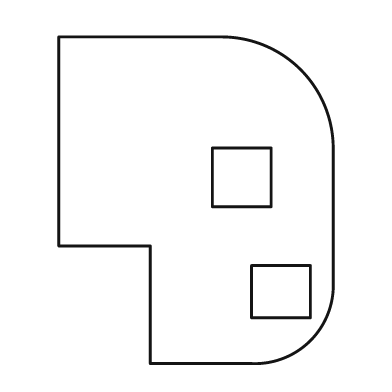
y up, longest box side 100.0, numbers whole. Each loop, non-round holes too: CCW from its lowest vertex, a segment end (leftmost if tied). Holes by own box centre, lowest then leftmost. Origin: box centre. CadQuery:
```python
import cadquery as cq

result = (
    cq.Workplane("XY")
    .moveTo(-14.0, -50.0)
    .lineTo(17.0, -50.0)
    .threePointArc((35.0, -43.0), (42.0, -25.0))
    .lineTo(42.0, 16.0)
    .threePointArc((32.0, 40.0), (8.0, 50.0))
    .lineTo(-42.0, 50.0)
    .lineTo(-42.0, -14.0)
    .lineTo(-14.0, -14.0)
    .close()
    .moveTo(17.0, -36.0)
    .lineTo(35.0, -36.0)
    .lineTo(35.0, -20.0)
    .lineTo(17.0, -20.0)
    .close()
    .moveTo(5.0, -2.0)
    .lineTo(23.0, -2.0)
    .lineTo(23.0, 16.0)
    .lineTo(5.0, 16.0)
    .close()
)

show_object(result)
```